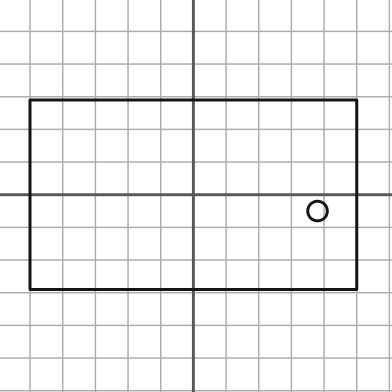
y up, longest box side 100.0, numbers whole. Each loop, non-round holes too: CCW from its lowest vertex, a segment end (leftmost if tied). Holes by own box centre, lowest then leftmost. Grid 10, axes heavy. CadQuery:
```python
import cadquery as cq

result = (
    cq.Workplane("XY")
    .moveTo(-50.0, -29.0)
    .lineTo(50.0, -29.0)
    .lineTo(50.0, 29.0)
    .lineTo(-50.0, 29.0)
    .close()
    .moveTo(38.0, -5.0)
    .circle(3.0)
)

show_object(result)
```